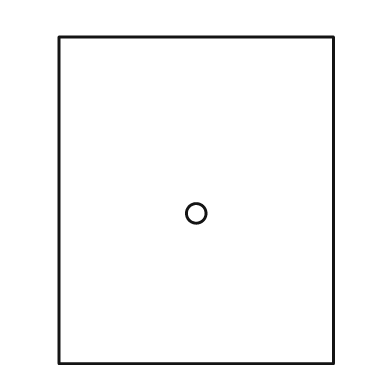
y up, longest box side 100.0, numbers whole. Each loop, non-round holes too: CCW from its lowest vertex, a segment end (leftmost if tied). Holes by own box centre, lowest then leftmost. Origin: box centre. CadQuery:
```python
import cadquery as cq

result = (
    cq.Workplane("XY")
    .moveTo(-42.0, -50.0)
    .lineTo(42.0, -50.0)
    .lineTo(42.0, 50.0)
    .lineTo(-42.0, 50.0)
    .close()
    .moveTo(0.0, -4.0)
    .circle(3.0)
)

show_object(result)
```